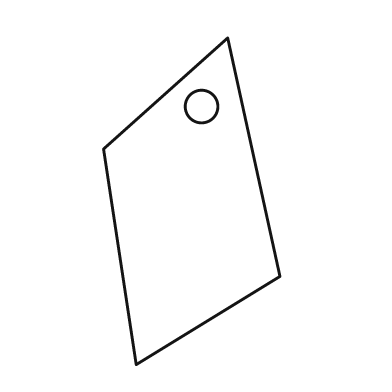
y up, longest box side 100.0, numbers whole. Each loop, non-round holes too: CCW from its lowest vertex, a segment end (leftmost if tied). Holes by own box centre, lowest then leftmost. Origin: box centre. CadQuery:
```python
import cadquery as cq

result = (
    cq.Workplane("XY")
    .moveTo(-17.0, -50.0)
    .lineTo(27.0, -23.0)
    .lineTo(11.0, 50.0)
    .lineTo(-27.0, 16.0)
    .close()
    .moveTo(3.0, 29.0)
    .circle(5.0)
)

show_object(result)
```